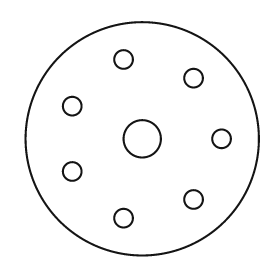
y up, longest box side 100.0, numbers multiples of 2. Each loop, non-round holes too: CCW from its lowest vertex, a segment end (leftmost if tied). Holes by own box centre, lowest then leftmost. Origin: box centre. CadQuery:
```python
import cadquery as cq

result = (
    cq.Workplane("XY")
    .moveTo(0.0, 0.0)
    .circle(50.0)
    .moveTo(-8.0, -34.0)
    .circle(4.0)
    .moveTo(22.0, -26.0)
    .circle(4.0)
    .moveTo(-30.0, -14.0)
    .circle(4.0)
    .moveTo(0.0, 0.0)
    .circle(8.0)
    .moveTo(34.0, 0.0)
    .circle(4.0)
    .moveTo(-30.0, 14.0)
    .circle(4.0)
    .moveTo(22.0, 26.0)
    .circle(4.0)
    .moveTo(-8.0, 34.0)
    .circle(4.0)
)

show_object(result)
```